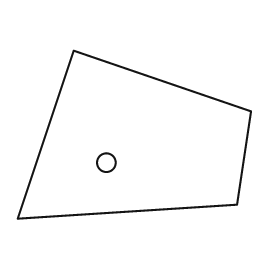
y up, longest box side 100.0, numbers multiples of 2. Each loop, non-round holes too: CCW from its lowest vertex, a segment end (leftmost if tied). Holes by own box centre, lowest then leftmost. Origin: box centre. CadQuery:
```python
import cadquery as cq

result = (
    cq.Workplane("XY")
    .moveTo(-50.0, -36.0)
    .lineTo(44.0, -30.0)
    .lineTo(50.0, 10.0)
    .lineTo(-26.0, 36.0)
    .close()
    .moveTo(-12.0, -12.0)
    .circle(4.0)
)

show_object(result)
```